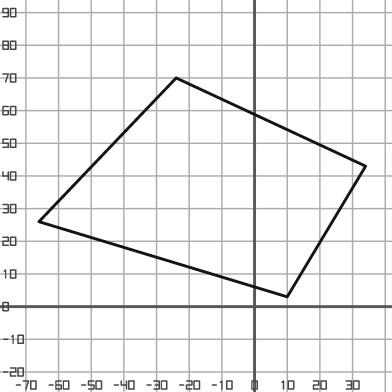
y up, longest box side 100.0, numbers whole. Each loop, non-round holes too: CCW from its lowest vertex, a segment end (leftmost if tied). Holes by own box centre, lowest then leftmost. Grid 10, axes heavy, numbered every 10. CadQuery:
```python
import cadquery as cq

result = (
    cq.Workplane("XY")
    .moveTo(10.0, 3.0)
    .lineTo(34.0, 43.0)
    .lineTo(-24.0, 70.0)
    .lineTo(-66.0, 26.0)
    .close()
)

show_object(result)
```